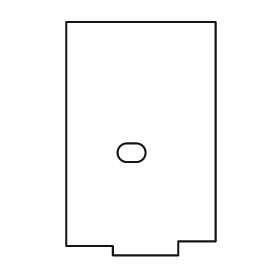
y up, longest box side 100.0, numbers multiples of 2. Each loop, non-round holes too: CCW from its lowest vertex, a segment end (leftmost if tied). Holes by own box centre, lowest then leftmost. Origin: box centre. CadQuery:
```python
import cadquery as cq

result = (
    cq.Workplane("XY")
    .moveTo(-12.0, -50.0)
    .lineTo(16.0, -50.0)
    .lineTo(16.0, -44.0)
    .lineTo(32.0, -44.0)
    .lineTo(32.0, 50.0)
    .lineTo(-32.0, 50.0)
    .lineTo(-32.0, -46.0)
    .lineTo(-12.0, -46.0)
    .close()
    .moveTo(-6.0, -10.0)
    .lineTo(-2.0, -10.0)
    .threePointArc((2.0, -6.0), (-2.0, -2.0))
    .lineTo(-6.0, -2.0)
    .threePointArc((-10.0, -6.0), (-6.0, -10.0))
    .close()
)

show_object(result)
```